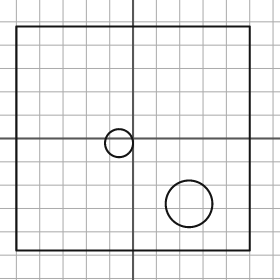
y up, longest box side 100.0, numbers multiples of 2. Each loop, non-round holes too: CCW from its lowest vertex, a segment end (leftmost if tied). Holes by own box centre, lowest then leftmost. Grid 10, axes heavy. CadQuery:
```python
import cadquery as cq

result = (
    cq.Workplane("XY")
    .moveTo(-50.0, -48.0)
    .lineTo(50.0, -48.0)
    .lineTo(50.0, 48.0)
    .lineTo(-50.0, 48.0)
    .close()
    .moveTo(24.0, -28.0)
    .circle(10.0)
    .moveTo(-6.0, -2.0)
    .circle(6.0)
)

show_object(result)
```